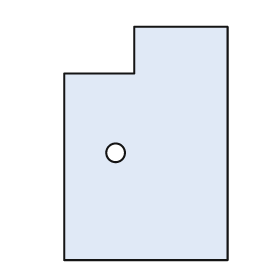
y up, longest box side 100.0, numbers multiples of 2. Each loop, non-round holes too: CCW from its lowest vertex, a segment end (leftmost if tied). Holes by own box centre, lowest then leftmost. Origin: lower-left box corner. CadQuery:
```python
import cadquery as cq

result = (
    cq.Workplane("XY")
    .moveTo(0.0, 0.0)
    .lineTo(70.0, 0.0)
    .lineTo(70.0, 100.0)
    .lineTo(30.0, 100.0)
    .lineTo(30.0, 80.0)
    .lineTo(0.0, 80.0)
    .close()
    .moveTo(22.0, 46.0)
    .circle(4.0)
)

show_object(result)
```